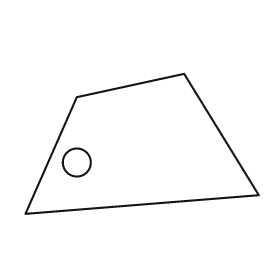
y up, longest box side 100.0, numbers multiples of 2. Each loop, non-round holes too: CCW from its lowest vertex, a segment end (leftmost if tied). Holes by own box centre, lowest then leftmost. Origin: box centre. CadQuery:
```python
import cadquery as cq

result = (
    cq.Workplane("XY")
    .moveTo(-50.0, -30.0)
    .lineTo(50.0, -22.0)
    .lineTo(18.0, 30.0)
    .lineTo(-28.0, 20.0)
    .close()
    .moveTo(-28.0, -8.0)
    .circle(6.0)
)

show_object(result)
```